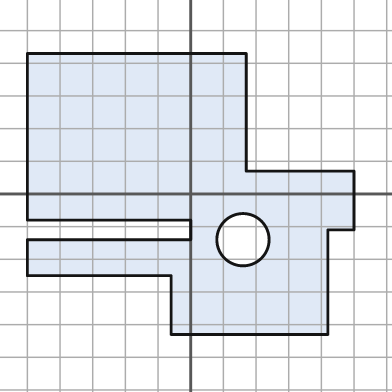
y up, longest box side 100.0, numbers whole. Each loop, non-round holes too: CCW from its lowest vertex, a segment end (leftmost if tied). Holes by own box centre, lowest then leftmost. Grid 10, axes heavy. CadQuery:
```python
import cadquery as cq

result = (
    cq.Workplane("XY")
    .moveTo(-6.0, -43.0)
    .lineTo(42.0, -43.0)
    .lineTo(42.0, -11.0)
    .lineTo(50.0, -11.0)
    .lineTo(50.0, 7.0)
    .lineTo(17.0, 7.0)
    .lineTo(17.0, 43.0)
    .lineTo(-50.0, 43.0)
    .lineTo(-50.0, -8.0)
    .lineTo(0.0, -8.0)
    .lineTo(0.0, -14.0)
    .lineTo(-50.0, -14.0)
    .lineTo(-50.0, -25.0)
    .lineTo(-6.0, -25.0)
    .close()
    .moveTo(16.0, -14.0)
    .circle(8.0)
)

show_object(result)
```